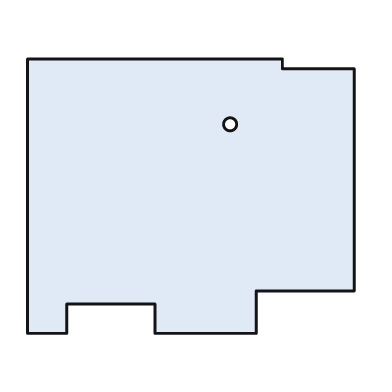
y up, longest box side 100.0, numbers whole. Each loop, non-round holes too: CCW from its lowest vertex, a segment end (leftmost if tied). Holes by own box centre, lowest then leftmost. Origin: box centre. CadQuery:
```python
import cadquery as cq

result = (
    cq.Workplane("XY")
    .moveTo(-50.0, -42.0)
    .lineTo(-38.0, -42.0)
    .lineTo(-38.0, -33.0)
    .lineTo(-11.0, -33.0)
    .lineTo(-11.0, -42.0)
    .lineTo(20.0, -42.0)
    .lineTo(20.0, -29.0)
    .lineTo(50.0, -29.0)
    .lineTo(50.0, 39.0)
    .lineTo(28.0, 39.0)
    .lineTo(28.0, 42.0)
    .lineTo(-50.0, 42.0)
    .close()
    .moveTo(12.0, 22.0)
    .circle(2.0)
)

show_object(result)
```